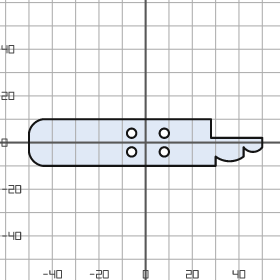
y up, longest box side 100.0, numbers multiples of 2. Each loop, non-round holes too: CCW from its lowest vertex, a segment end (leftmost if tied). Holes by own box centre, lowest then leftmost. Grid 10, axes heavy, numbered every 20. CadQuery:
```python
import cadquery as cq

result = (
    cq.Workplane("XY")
    .moveTo(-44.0, -10.0)
    .lineTo(30.0, -10.0)
    .lineTo(30.0, -6.0)
    .threePointArc((36.0, -8.0), (42.0, -6.0))
    .lineTo(42.0, -2.0)
    .threePointArc((46.0, -4.0), (50.0, -2.0))
    .lineTo(50.0, 2.0)
    .lineTo(28.0, 2.0)
    .lineTo(28.0, 10.0)
    .lineTo(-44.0, 10.0)
    .threePointArc((-48.0, 8.0), (-50.0, 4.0))
    .lineTo(-50.0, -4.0)
    .threePointArc((-48.0, -8.0), (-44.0, -10.0))
    .close()
    .moveTo(-6.0, -4.0)
    .circle(2.0)
    .moveTo(8.0, -4.0)
    .circle(2.0)
    .moveTo(-6.0, 4.0)
    .circle(2.0)
    .moveTo(8.0, 4.0)
    .circle(2.0)
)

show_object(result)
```